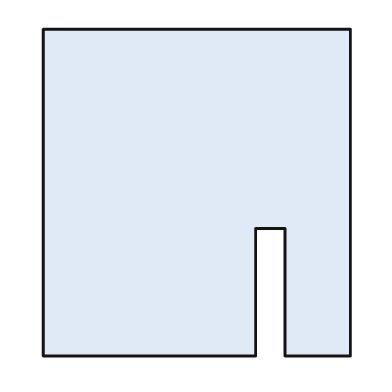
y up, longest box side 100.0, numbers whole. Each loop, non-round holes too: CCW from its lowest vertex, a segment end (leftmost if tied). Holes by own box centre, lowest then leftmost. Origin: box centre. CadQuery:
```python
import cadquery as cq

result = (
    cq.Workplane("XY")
    .moveTo(-47.0, -50.0)
    .lineTo(18.0, -50.0)
    .lineTo(18.0, -11.0)
    .lineTo(27.0, -11.0)
    .lineTo(27.0, -50.0)
    .lineTo(47.0, -50.0)
    .lineTo(47.0, 50.0)
    .lineTo(-47.0, 50.0)
    .close()
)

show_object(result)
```